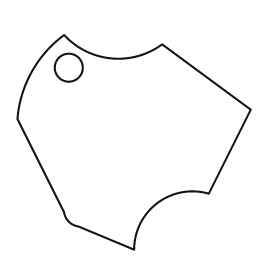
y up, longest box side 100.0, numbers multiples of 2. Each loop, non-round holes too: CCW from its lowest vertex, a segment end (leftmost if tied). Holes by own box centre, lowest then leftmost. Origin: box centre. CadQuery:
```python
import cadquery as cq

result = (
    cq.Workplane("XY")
    .moveTo(0.0, -46.0)
    .threePointArc((10.0, -26.0), (32.0, -22.0))
    .lineTo(50.0, 14.0)
    .lineTo(12.0, 42.0)
    .threePointArc((-10.0, 36.0), (-30.0, 46.0))
    .threePointArc((-44.0, 30.0), (-50.0, 10.0))
    .lineTo(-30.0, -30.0)
    .threePointArc((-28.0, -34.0), (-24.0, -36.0))
    .close()
    .moveTo(-28.0, 32.0)
    .circle(6.0)
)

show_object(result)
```